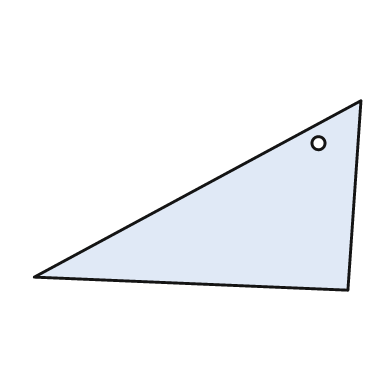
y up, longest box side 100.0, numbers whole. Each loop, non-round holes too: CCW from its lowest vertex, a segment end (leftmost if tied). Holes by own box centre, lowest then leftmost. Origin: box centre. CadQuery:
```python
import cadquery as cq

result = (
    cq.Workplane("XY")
    .moveTo(46.0, -29.0)
    .lineTo(50.0, 29.0)
    .lineTo(-50.0, -25.0)
    .close()
    .moveTo(37.0, 16.0)
    .circle(2.0)
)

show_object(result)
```